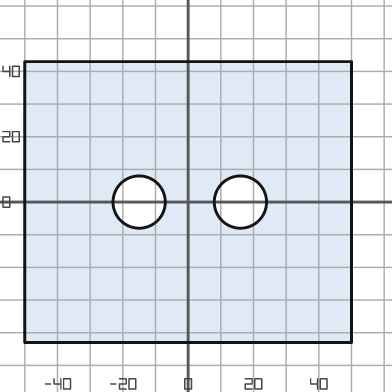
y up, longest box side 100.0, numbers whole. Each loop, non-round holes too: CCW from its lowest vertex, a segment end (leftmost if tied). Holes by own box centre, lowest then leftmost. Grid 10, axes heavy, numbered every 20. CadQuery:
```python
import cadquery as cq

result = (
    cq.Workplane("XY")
    .moveTo(-50.0, -43.0)
    .lineTo(50.0, -43.0)
    .lineTo(50.0, 43.0)
    .lineTo(-50.0, 43.0)
    .close()
    .moveTo(-15.0, 0.0)
    .circle(8.0)
    .moveTo(16.0, 0.0)
    .circle(8.0)
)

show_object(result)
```